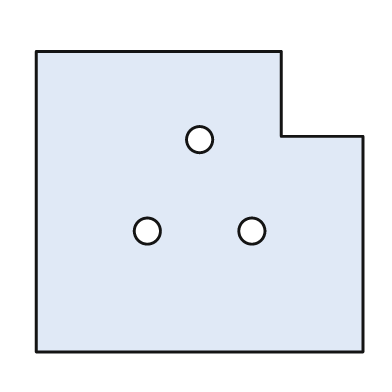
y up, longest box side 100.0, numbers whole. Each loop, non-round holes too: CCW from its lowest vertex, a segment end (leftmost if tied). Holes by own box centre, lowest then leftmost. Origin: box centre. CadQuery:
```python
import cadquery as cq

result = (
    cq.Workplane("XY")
    .moveTo(-50.0, -46.0)
    .lineTo(50.0, -46.0)
    .lineTo(50.0, 20.0)
    .lineTo(25.0, 20.0)
    .lineTo(25.0, 46.0)
    .lineTo(-50.0, 46.0)
    .close()
    .moveTo(-16.0, -9.0)
    .circle(4.0)
    .moveTo(16.0, -9.0)
    .circle(4.0)
    .moveTo(0.0, 19.0)
    .circle(4.0)
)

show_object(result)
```